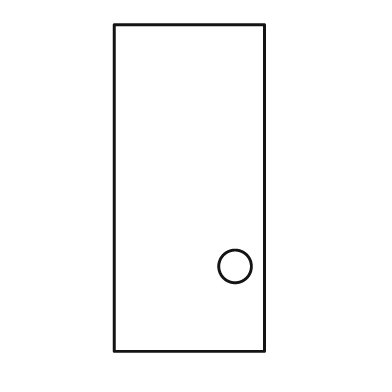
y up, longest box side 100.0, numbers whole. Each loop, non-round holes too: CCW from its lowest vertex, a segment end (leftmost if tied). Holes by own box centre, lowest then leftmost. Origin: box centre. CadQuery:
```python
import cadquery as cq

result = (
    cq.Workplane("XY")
    .moveTo(-23.0, -50.0)
    .lineTo(23.0, -50.0)
    .lineTo(23.0, 50.0)
    .lineTo(-23.0, 50.0)
    .close()
    .moveTo(14.0, -24.0)
    .circle(5.0)
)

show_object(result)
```